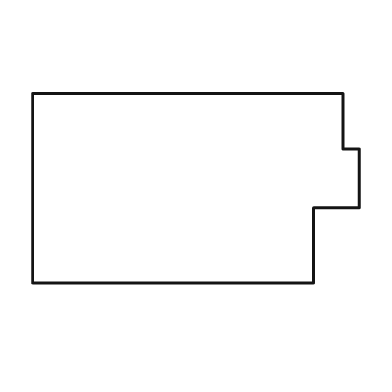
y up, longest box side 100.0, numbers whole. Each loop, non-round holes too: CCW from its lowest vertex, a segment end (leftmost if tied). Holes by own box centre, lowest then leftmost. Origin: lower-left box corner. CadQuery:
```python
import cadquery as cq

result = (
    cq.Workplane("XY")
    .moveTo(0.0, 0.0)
    .lineTo(86.0, 0.0)
    .lineTo(86.0, 23.0)
    .lineTo(100.0, 23.0)
    .lineTo(100.0, 41.0)
    .lineTo(95.0, 41.0)
    .lineTo(95.0, 58.0)
    .lineTo(0.0, 58.0)
    .close()
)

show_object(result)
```